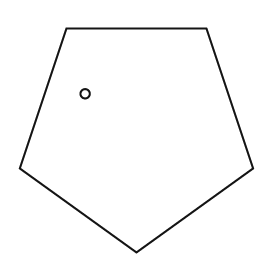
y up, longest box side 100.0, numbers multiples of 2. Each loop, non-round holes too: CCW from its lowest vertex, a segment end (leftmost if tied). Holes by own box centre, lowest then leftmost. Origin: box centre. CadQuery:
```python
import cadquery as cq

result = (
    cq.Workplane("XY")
    .moveTo(0.0, -48.0)
    .lineTo(50.0, -12.0)
    .lineTo(30.0, 48.0)
    .lineTo(-30.0, 48.0)
    .lineTo(-50.0, -12.0)
    .close()
    .moveTo(-22.0, 20.0)
    .circle(2.0)
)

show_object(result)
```